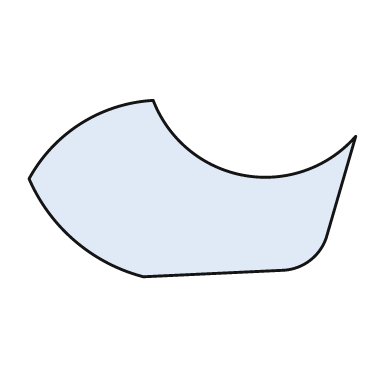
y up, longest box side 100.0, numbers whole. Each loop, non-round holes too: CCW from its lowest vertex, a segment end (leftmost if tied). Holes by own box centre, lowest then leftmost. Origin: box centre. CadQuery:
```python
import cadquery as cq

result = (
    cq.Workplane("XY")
    .moveTo(-15.0, -27.0)
    .lineTo(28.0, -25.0)
    .threePointArc((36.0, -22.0), (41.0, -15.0))
    .lineTo(50.0, 16.0)
    .threePointArc((16.0, 4.0), (-12.0, 27.0))
    .threePointArc((-34.0, 20.0), (-50.0, 3.0))
    .threePointArc((-36.0, -16.0), (-15.0, -27.0))
    .close()
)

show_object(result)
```